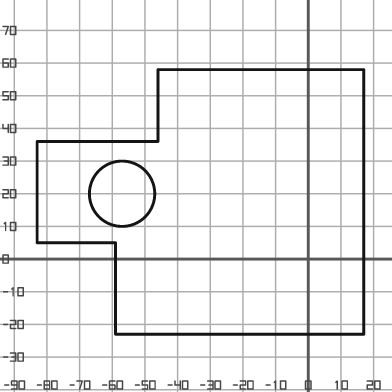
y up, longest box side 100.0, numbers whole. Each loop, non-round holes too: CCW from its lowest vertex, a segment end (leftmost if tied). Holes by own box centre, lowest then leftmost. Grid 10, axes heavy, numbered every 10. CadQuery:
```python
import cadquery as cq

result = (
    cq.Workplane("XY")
    .moveTo(-59.0, -23.0)
    .lineTo(17.0, -23.0)
    .lineTo(17.0, 58.0)
    .lineTo(-46.0, 58.0)
    .lineTo(-46.0, 36.0)
    .lineTo(-83.0, 36.0)
    .lineTo(-83.0, 5.0)
    .lineTo(-59.0, 5.0)
    .close()
    .moveTo(-57.0, 20.0)
    .circle(10.0)
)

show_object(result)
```